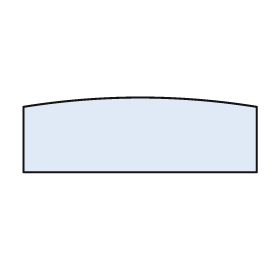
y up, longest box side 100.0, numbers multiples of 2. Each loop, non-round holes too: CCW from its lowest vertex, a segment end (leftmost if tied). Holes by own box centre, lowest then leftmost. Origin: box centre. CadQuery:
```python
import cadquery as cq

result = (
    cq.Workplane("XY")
    .moveTo(-50.0, -16.0)
    .lineTo(50.0, -16.0)
    .lineTo(50.0, 12.0)
    .threePointArc((0.0, 16.0), (-50.0, 12.0))
    .close()
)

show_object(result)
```